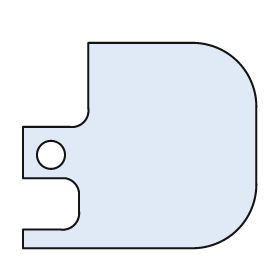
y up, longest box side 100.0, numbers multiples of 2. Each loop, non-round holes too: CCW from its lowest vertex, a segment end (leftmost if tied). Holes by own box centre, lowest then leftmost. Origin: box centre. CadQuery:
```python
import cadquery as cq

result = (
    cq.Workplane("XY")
    .moveTo(-50.0, -44.0)
    .lineTo(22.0, -44.0)
    .threePointArc((42.0, -36.0), (50.0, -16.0))
    .lineTo(50.0, 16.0)
    .threePointArc((42.0, 36.0), (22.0, 44.0))
    .lineTo(-22.0, 44.0)
    .lineTo(-22.0, 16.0)
    .threePointArc((-24.0, 10.0), (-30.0, 8.0))
    .lineTo(-50.0, 8.0)
    .lineTo(-50.0, -14.0)
    .lineTo(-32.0, -14.0)
    .threePointArc((-28.0, -16.0), (-26.0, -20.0))
    .lineTo(-26.0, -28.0)
    .threePointArc((-28.0, -34.0), (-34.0, -36.0))
    .lineTo(-50.0, -36.0)
    .close()
    .moveTo(-38.0, -4.0)
    .circle(6.0)
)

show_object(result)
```